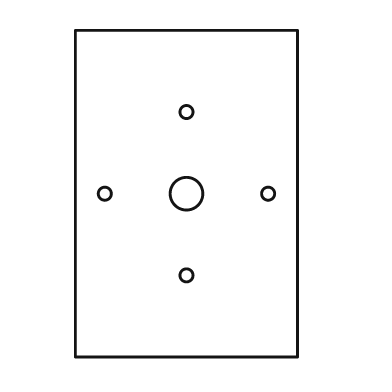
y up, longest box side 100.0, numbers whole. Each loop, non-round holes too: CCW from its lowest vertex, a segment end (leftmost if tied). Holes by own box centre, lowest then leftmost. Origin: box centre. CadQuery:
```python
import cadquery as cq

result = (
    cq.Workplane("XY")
    .moveTo(-34.0, -50.0)
    .lineTo(34.0, -50.0)
    .lineTo(34.0, 50.0)
    .lineTo(-34.0, 50.0)
    .close()
    .moveTo(0.0, -25.0)
    .circle(2.0)
    .moveTo(-25.0, 0.0)
    .circle(2.0)
    .moveTo(0.0, 0.0)
    .circle(5.0)
    .moveTo(25.0, 0.0)
    .circle(2.0)
    .moveTo(0.0, 25.0)
    .circle(2.0)
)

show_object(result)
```